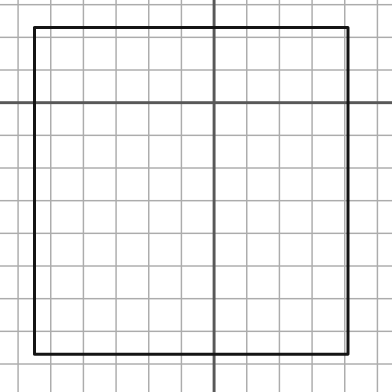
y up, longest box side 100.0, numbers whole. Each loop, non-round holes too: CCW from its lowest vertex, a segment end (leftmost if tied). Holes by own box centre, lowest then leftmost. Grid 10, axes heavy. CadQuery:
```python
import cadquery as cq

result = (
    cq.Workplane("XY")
    .moveTo(-55.0, -77.0)
    .lineTo(41.0, -77.0)
    .lineTo(41.0, 23.0)
    .lineTo(-55.0, 23.0)
    .close()
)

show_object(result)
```